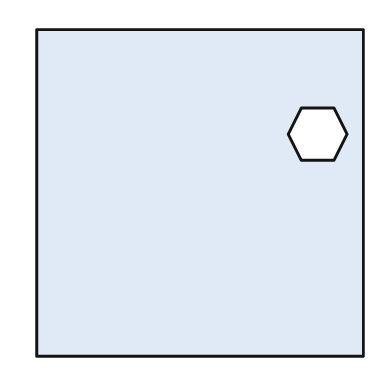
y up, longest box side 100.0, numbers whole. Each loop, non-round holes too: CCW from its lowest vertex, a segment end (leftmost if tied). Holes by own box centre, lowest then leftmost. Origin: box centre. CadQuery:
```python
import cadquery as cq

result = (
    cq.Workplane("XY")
    .moveTo(-50.0, -50.0)
    .lineTo(50.0, -50.0)
    .lineTo(50.0, 50.0)
    .lineTo(-50.0, 50.0)
    .close()
    .moveTo(31.0, 10.0)
    .lineTo(41.0, 10.0)
    .lineTo(45.0, 18.0)
    .lineTo(41.0, 26.0)
    .lineTo(31.0, 26.0)
    .lineTo(27.0, 18.0)
    .close()
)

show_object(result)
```